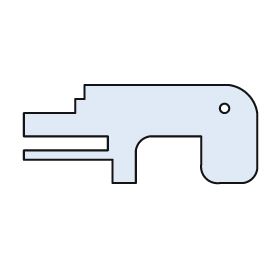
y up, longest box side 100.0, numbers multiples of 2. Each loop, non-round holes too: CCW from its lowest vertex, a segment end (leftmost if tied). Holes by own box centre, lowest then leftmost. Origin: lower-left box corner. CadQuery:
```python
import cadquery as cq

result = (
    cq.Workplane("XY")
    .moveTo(38.0, 0.0)
    .lineTo(48.0, 0.0)
    .lineTo(48.0, 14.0)
    .threePointArc((50.0, 18.0), (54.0, 20.0))
    .lineTo(76.0, 20.0)
    .lineTo(76.0, 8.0)
    .threePointArc((78.0, 2.0), (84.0, 0.0))
    .lineTo(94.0, 0.0)
    .threePointArc((98.0, 2.0), (100.0, 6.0))
    .lineTo(100.0, 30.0)
    .threePointArc((96.0, 38.0), (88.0, 42.0))
    .lineTo(26.0, 42.0)
    .lineTo(26.0, 36.0)
    .lineTo(22.0, 36.0)
    .lineTo(22.0, 30.0)
    .lineTo(0.0, 30.0)
    .lineTo(0.0, 20.0)
    .lineTo(36.0, 20.0)
    .lineTo(36.0, 14.0)
    .lineTo(0.0, 14.0)
    .lineTo(0.0, 10.0)
    .lineTo(38.0, 10.0)
    .close()
    .moveTo(86.0, 32.0)
    .circle(2.0)
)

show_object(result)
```